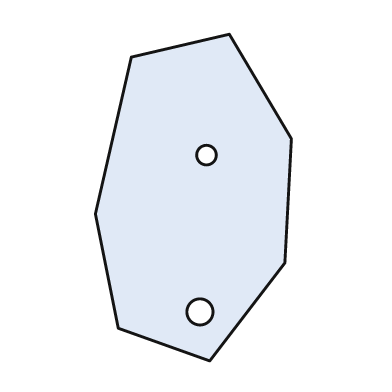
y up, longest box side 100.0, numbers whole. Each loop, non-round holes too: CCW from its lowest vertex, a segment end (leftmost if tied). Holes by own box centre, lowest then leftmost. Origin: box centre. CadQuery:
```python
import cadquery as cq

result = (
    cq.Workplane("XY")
    .moveTo(5.0, -50.0)
    .lineTo(28.0, -20.0)
    .lineTo(30.0, 18.0)
    .lineTo(11.0, 50.0)
    .lineTo(-19.0, 43.0)
    .lineTo(-30.0, -5.0)
    .lineTo(-23.0, -40.0)
    .close()
    .moveTo(2.0, -35.0)
    .circle(4.0)
    .moveTo(4.0, 13.0)
    .circle(3.0)
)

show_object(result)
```